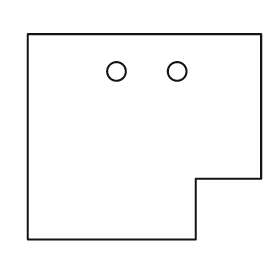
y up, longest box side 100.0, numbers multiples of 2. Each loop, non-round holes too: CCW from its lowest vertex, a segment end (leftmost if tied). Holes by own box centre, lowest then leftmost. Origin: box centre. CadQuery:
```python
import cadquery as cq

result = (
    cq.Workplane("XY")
    .moveTo(-50.0, -44.0)
    .lineTo(22.0, -44.0)
    .lineTo(22.0, -18.0)
    .lineTo(50.0, -18.0)
    .lineTo(50.0, 44.0)
    .lineTo(-50.0, 44.0)
    .close()
    .moveTo(-12.0, 28.0)
    .circle(4.0)
    .moveTo(14.0, 28.0)
    .circle(4.0)
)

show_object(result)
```